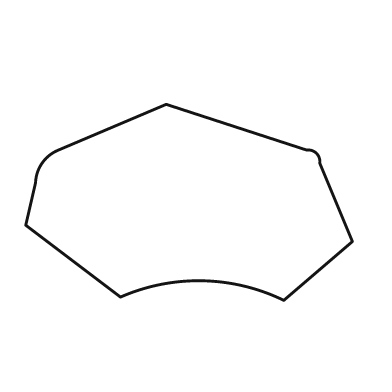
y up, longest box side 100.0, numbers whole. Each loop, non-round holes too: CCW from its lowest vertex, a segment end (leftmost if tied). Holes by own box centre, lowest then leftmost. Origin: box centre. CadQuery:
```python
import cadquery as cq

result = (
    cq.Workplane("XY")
    .moveTo(29.0, -30.0)
    .lineTo(50.0, -12.0)
    .lineTo(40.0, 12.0)
    .threePointArc((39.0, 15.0), (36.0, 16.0))
    .lineTo(-7.0, 30.0)
    .lineTo(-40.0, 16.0)
    .threePointArc((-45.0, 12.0), (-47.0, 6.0))
    .lineTo(-50.0, -7.0)
    .lineTo(-21.0, -29.0)
    .threePointArc((4.0, -24.0), (29.0, -30.0))
    .close()
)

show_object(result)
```